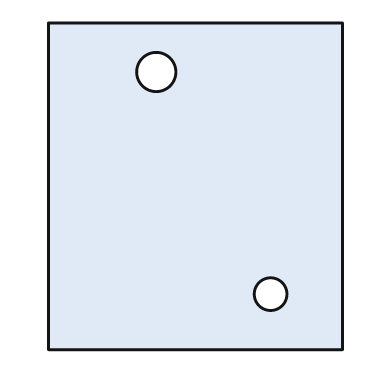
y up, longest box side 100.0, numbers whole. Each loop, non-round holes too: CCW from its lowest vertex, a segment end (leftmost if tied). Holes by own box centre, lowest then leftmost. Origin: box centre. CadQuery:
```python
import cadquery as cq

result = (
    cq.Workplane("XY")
    .moveTo(-45.0, -50.0)
    .lineTo(45.0, -50.0)
    .lineTo(45.0, 50.0)
    .lineTo(-45.0, 50.0)
    .close()
    .moveTo(23.0, -33.0)
    .circle(5.0)
    .moveTo(-12.0, 35.0)
    .circle(6.0)
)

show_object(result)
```